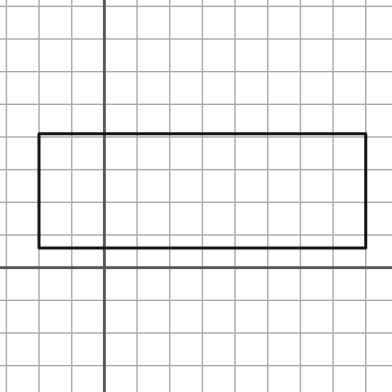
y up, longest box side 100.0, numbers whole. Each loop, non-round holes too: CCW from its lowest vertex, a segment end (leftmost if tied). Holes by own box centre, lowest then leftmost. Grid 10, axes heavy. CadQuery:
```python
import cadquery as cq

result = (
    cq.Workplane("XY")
    .moveTo(-20.0, 6.0)
    .lineTo(80.0, 6.0)
    .lineTo(80.0, 41.0)
    .lineTo(-20.0, 41.0)
    .close()
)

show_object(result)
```